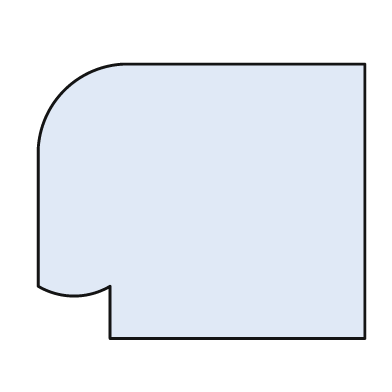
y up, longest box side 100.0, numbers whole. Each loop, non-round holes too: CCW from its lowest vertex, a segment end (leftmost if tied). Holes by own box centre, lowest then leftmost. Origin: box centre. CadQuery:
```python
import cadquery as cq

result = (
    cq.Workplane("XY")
    .moveTo(-28.0, -42.0)
    .lineTo(50.0, -42.0)
    .lineTo(50.0, 42.0)
    .lineTo(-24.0, 42.0)
    .threePointArc((-42.0, 34.0), (-50.0, 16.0))
    .lineTo(-50.0, -26.0)
    .threePointArc((-39.0, -29.0), (-28.0, -26.0))
    .close()
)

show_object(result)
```